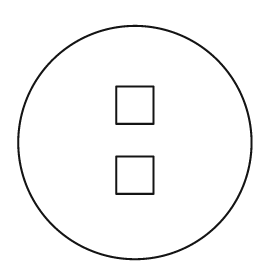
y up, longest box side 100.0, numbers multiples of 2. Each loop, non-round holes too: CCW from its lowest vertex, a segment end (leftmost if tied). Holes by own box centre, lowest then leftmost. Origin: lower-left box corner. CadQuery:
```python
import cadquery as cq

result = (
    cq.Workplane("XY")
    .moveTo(50.0, 50.0)
    .circle(50.0)
    .moveTo(42.0, 28.0)
    .lineTo(58.0, 28.0)
    .lineTo(58.0, 44.0)
    .lineTo(42.0, 44.0)
    .close()
    .moveTo(42.0, 58.0)
    .lineTo(58.0, 58.0)
    .lineTo(58.0, 74.0)
    .lineTo(42.0, 74.0)
    .close()
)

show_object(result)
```